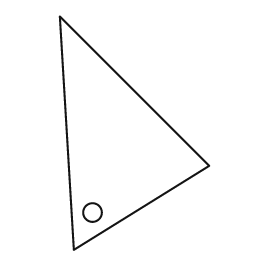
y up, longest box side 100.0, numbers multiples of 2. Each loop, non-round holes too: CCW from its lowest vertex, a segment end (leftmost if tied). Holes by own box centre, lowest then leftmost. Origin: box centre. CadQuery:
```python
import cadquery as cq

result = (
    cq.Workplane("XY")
    .moveTo(-26.0, -50.0)
    .lineTo(32.0, -14.0)
    .lineTo(-32.0, 50.0)
    .close()
    .moveTo(-18.0, -34.0)
    .circle(4.0)
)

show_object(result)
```